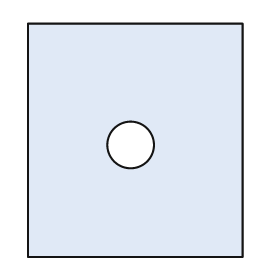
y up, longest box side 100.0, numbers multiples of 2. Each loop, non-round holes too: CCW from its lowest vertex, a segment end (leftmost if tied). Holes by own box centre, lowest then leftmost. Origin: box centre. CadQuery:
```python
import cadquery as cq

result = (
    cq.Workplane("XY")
    .moveTo(-46.0, -50.0)
    .lineTo(46.0, -50.0)
    .lineTo(46.0, 50.0)
    .lineTo(-46.0, 50.0)
    .close()
    .moveTo(-2.0, -2.0)
    .circle(10.0)
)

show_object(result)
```